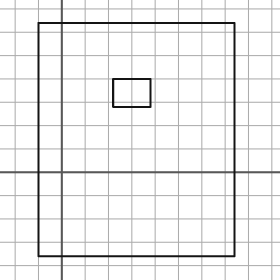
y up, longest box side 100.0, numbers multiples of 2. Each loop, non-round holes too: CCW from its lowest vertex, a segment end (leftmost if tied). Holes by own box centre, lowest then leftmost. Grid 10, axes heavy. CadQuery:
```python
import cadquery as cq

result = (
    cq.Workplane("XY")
    .moveTo(-10.0, -36.0)
    .lineTo(74.0, -36.0)
    .lineTo(74.0, 64.0)
    .lineTo(-10.0, 64.0)
    .close()
    .moveTo(22.0, 28.0)
    .lineTo(38.0, 28.0)
    .lineTo(38.0, 40.0)
    .lineTo(22.0, 40.0)
    .close()
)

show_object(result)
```